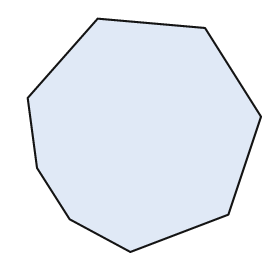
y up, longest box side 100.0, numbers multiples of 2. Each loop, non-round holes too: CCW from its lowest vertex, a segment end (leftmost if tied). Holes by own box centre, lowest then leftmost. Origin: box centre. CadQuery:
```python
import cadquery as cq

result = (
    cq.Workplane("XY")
    .moveTo(-6.0, -50.0)
    .lineTo(36.0, -34.0)
    .lineTo(50.0, 8.0)
    .lineTo(26.0, 46.0)
    .lineTo(-20.0, 50.0)
    .lineTo(-50.0, 16.0)
    .lineTo(-46.0, -14.0)
    .lineTo(-32.0, -36.0)
    .close()
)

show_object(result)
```